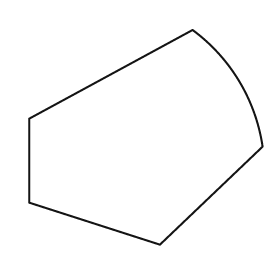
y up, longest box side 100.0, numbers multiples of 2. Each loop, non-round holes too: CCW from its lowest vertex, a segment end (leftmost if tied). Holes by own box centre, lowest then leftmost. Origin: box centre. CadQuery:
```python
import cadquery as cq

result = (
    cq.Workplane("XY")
    .moveTo(6.0, -46.0)
    .lineTo(50.0, -4.0)
    .threePointArc((40.0, 24.0), (20.0, 46.0))
    .lineTo(-50.0, 8.0)
    .lineTo(-50.0, -28.0)
    .close()
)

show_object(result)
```